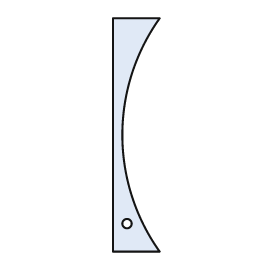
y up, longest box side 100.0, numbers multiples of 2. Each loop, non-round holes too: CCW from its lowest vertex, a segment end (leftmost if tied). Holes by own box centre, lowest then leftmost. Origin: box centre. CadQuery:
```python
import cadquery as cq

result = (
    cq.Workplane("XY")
    .moveTo(-10.0, -50.0)
    .lineTo(10.0, -50.0)
    .threePointArc((-6.0, 0.0), (10.0, 50.0))
    .lineTo(-10.0, 50.0)
    .close()
    .moveTo(-4.0, -38.0)
    .circle(2.0)
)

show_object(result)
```